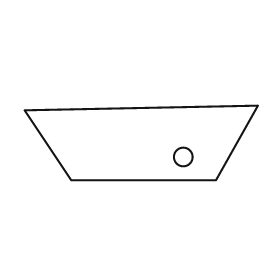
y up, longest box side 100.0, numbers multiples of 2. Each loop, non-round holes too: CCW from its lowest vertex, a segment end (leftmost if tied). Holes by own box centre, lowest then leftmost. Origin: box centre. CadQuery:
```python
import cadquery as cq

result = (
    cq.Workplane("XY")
    .moveTo(-30.0, -16.0)
    .lineTo(32.0, -16.0)
    .lineTo(50.0, 16.0)
    .lineTo(-50.0, 14.0)
    .close()
    .moveTo(18.0, -6.0)
    .circle(4.0)
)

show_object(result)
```